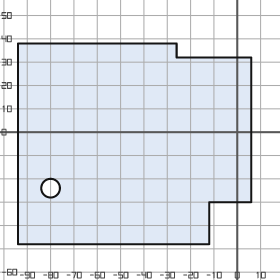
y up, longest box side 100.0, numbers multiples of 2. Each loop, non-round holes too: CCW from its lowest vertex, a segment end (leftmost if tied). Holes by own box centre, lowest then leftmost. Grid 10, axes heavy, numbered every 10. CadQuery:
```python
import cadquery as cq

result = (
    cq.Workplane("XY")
    .moveTo(-94.0, -48.0)
    .lineTo(-12.0, -48.0)
    .lineTo(-12.0, -30.0)
    .lineTo(6.0, -30.0)
    .lineTo(6.0, 32.0)
    .lineTo(-26.0, 32.0)
    .lineTo(-26.0, 38.0)
    .lineTo(-94.0, 38.0)
    .close()
    .moveTo(-80.0, -24.0)
    .circle(4.0)
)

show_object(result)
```